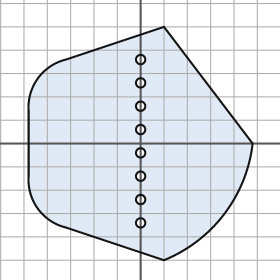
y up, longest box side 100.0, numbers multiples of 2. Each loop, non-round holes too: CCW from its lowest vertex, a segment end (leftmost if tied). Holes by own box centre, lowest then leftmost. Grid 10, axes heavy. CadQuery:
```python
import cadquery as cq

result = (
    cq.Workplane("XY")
    .moveTo(10.0, -50.0)
    .threePointArc((36.0, -30.0), (48.0, 0.0))
    .lineTo(10.0, 50.0)
    .lineTo(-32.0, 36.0)
    .threePointArc((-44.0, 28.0), (-48.0, 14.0))
    .lineTo(-48.0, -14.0)
    .threePointArc((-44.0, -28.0), (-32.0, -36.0))
    .close()
    .moveTo(0.0, -34.0)
    .circle(2.0)
    .moveTo(0.0, -24.0)
    .circle(2.0)
    .moveTo(0.0, -14.0)
    .circle(2.0)
    .moveTo(0.0, -4.0)
    .circle(2.0)
    .moveTo(0.0, 6.0)
    .circle(2.0)
    .moveTo(0.0, 16.0)
    .circle(2.0)
    .moveTo(0.0, 26.0)
    .circle(2.0)
    .moveTo(0.0, 36.0)
    .circle(2.0)
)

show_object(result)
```